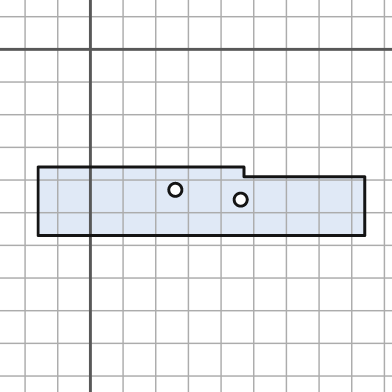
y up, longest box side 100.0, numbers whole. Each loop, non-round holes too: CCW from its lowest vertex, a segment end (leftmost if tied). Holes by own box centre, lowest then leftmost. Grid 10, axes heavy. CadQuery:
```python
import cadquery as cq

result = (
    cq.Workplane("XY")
    .moveTo(-16.0, -57.0)
    .lineTo(84.0, -57.0)
    .lineTo(84.0, -39.0)
    .lineTo(47.0, -39.0)
    .lineTo(47.0, -36.0)
    .lineTo(-16.0, -36.0)
    .close()
    .moveTo(46.0, -46.0)
    .circle(2.0)
    .moveTo(26.0, -43.0)
    .circle(2.0)
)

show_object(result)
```